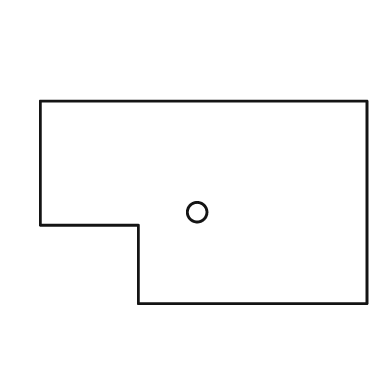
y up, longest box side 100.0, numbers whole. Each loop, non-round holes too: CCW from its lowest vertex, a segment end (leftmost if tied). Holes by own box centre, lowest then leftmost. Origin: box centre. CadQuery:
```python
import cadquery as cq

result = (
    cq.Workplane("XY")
    .moveTo(-20.0, -31.0)
    .lineTo(50.0, -31.0)
    .lineTo(50.0, 31.0)
    .lineTo(-50.0, 31.0)
    .lineTo(-50.0, -7.0)
    .lineTo(-20.0, -7.0)
    .close()
    .moveTo(-2.0, -3.0)
    .circle(3.0)
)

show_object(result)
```